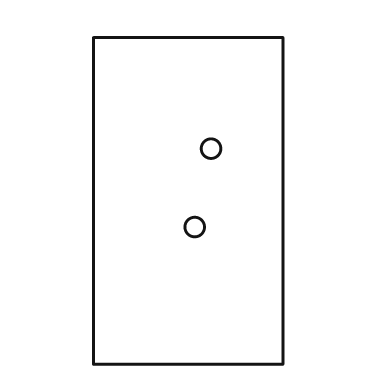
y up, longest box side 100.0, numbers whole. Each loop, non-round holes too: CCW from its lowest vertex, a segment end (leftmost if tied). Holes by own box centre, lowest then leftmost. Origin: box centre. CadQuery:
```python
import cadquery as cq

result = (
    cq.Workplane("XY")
    .moveTo(-29.0, -50.0)
    .lineTo(29.0, -50.0)
    .lineTo(29.0, 50.0)
    .lineTo(-29.0, 50.0)
    .close()
    .moveTo(2.0, -8.0)
    .circle(3.0)
    .moveTo(7.0, 16.0)
    .circle(3.0)
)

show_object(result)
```